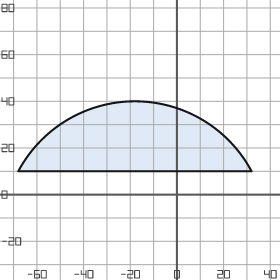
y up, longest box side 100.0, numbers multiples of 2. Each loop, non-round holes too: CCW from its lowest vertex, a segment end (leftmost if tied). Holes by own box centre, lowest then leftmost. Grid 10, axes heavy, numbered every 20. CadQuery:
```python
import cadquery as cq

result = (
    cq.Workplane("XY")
    .moveTo(-68.0, 10.0)
    .lineTo(32.0, 10.0)
    .threePointArc((-18.0, 40.0), (-68.0, 10.0))
    .close()
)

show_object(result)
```